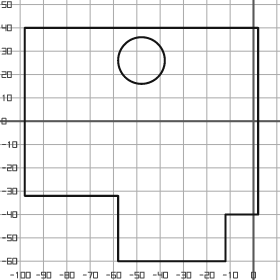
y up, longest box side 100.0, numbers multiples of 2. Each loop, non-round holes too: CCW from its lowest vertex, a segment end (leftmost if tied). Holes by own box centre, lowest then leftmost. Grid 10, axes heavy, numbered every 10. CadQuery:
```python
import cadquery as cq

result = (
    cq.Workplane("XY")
    .moveTo(-58.0, -60.0)
    .lineTo(-12.0, -60.0)
    .lineTo(-12.0, -40.0)
    .lineTo(2.0, -40.0)
    .lineTo(2.0, 40.0)
    .lineTo(-98.0, 40.0)
    .lineTo(-98.0, -32.0)
    .lineTo(-58.0, -32.0)
    .close()
    .moveTo(-48.0, 26.0)
    .circle(10.0)
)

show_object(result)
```